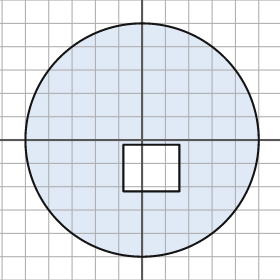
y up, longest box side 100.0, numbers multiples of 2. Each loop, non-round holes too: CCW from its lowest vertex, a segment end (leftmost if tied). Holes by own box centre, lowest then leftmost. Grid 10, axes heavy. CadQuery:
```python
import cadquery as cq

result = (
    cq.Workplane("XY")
    .moveTo(0.0, 0.0)
    .circle(50.0)
    .moveTo(-8.0, -22.0)
    .lineTo(16.0, -22.0)
    .lineTo(16.0, -2.0)
    .lineTo(-8.0, -2.0)
    .close()
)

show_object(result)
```